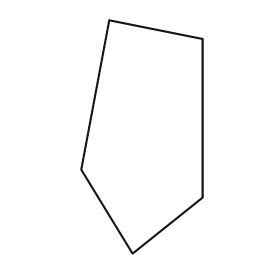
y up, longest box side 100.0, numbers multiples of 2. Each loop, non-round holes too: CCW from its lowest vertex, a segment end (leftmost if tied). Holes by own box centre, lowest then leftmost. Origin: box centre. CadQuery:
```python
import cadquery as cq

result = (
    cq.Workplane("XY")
    .moveTo(-4.0, -50.0)
    .lineTo(26.0, -26.0)
    .lineTo(26.0, 42.0)
    .lineTo(-14.0, 50.0)
    .lineTo(-26.0, -14.0)
    .close()
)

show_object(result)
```